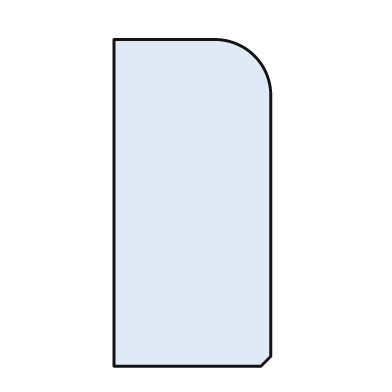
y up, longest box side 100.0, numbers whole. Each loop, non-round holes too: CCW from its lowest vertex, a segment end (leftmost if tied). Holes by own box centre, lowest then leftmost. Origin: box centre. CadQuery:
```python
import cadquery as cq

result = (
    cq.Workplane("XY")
    .moveTo(-24.0, -50.0)
    .lineTo(21.0, -50.0)
    .lineTo(24.0, -47.0)
    .lineTo(24.0, 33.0)
    .threePointArc((19.0, 45.0), (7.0, 50.0))
    .lineTo(-24.0, 50.0)
    .close()
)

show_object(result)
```